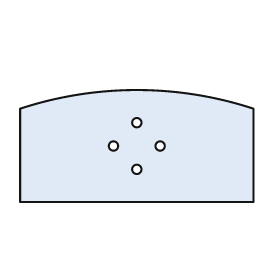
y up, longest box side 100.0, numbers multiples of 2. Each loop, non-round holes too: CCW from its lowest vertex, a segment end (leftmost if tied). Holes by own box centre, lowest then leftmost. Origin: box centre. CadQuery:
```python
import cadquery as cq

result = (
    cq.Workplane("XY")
    .moveTo(-50.0, -24.0)
    .lineTo(50.0, -24.0)
    .lineTo(50.0, 16.0)
    .threePointArc((0.0, 24.0), (-50.0, 16.0))
    .close()
    .moveTo(0.0, -10.0)
    .circle(2.0)
    .moveTo(-10.0, 0.0)
    .circle(2.0)
    .moveTo(10.0, 0.0)
    .circle(2.0)
    .moveTo(0.0, 10.0)
    .circle(2.0)
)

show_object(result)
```